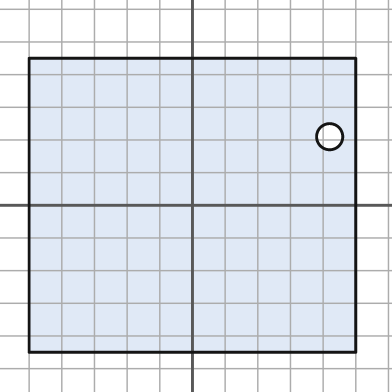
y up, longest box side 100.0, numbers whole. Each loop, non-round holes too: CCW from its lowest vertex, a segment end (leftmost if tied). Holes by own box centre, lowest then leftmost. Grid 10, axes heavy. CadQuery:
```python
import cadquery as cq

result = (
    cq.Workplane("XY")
    .moveTo(-50.0, -45.0)
    .lineTo(50.0, -45.0)
    .lineTo(50.0, 45.0)
    .lineTo(-50.0, 45.0)
    .close()
    .moveTo(42.0, 21.0)
    .circle(4.0)
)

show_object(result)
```